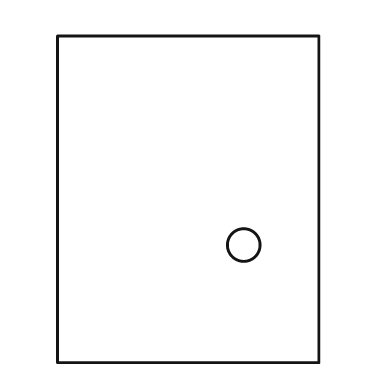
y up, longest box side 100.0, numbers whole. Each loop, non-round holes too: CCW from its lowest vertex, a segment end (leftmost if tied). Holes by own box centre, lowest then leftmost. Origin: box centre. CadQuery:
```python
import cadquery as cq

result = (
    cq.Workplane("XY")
    .moveTo(-40.0, -50.0)
    .lineTo(40.0, -50.0)
    .lineTo(40.0, 50.0)
    .lineTo(-40.0, 50.0)
    .close()
    .moveTo(17.0, -14.0)
    .circle(5.0)
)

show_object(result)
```